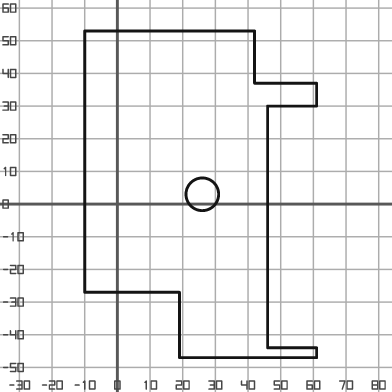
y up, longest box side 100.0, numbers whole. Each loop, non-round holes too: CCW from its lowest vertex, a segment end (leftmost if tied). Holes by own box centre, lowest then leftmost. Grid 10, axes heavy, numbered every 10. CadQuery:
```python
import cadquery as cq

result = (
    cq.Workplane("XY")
    .moveTo(19.0, -47.0)
    .lineTo(61.0, -47.0)
    .lineTo(61.0, -44.0)
    .lineTo(46.0, -44.0)
    .lineTo(46.0, 30.0)
    .lineTo(61.0, 30.0)
    .lineTo(61.0, 37.0)
    .lineTo(42.0, 37.0)
    .lineTo(42.0, 53.0)
    .lineTo(-10.0, 53.0)
    .lineTo(-10.0, -27.0)
    .lineTo(19.0, -27.0)
    .close()
    .moveTo(26.0, 3.0)
    .circle(5.0)
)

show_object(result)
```